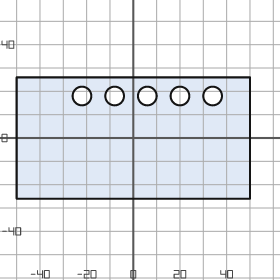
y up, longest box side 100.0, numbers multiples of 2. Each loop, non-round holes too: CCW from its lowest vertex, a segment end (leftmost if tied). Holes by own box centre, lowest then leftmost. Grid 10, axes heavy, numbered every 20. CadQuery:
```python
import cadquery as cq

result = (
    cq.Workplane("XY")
    .moveTo(-50.0, -26.0)
    .lineTo(50.0, -26.0)
    .lineTo(50.0, 26.0)
    .lineTo(-50.0, 26.0)
    .close()
    .moveTo(-22.0, 18.0)
    .circle(4.0)
    .moveTo(-8.0, 18.0)
    .circle(4.0)
    .moveTo(6.0, 18.0)
    .circle(4.0)
    .moveTo(20.0, 18.0)
    .circle(4.0)
    .moveTo(34.0, 18.0)
    .circle(4.0)
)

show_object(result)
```